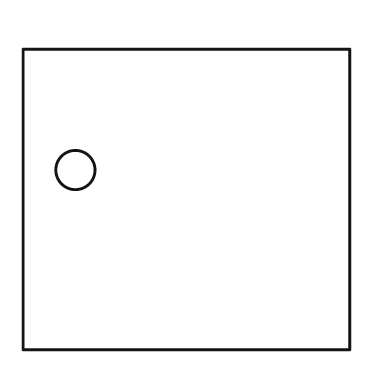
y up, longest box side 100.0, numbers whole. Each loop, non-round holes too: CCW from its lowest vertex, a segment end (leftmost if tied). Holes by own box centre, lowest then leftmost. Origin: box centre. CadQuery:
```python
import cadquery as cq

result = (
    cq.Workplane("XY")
    .moveTo(-50.0, -46.0)
    .lineTo(50.0, -46.0)
    .lineTo(50.0, 46.0)
    .lineTo(-50.0, 46.0)
    .close()
    .moveTo(-34.0, 9.0)
    .circle(6.0)
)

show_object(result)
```